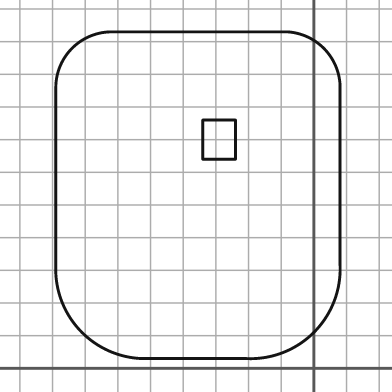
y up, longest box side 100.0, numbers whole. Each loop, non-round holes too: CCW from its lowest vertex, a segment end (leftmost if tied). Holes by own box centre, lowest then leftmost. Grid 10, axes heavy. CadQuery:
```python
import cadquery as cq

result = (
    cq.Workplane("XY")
    .moveTo(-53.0, 3.0)
    .lineTo(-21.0, 3.0)
    .threePointArc((0.0, 11.0), (8.0, 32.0))
    .lineTo(8.0, 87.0)
    .threePointArc((3.0, 98.0), (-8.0, 103.0))
    .lineTo(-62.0, 103.0)
    .threePointArc((-74.0, 98.0), (-79.0, 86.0))
    .lineTo(-79.0, 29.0)
    .threePointArc((-71.0, 11.0), (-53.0, 3.0))
    .close()
    .moveTo(-34.0, 64.0)
    .lineTo(-24.0, 64.0)
    .lineTo(-24.0, 76.0)
    .lineTo(-34.0, 76.0)
    .close()
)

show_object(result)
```